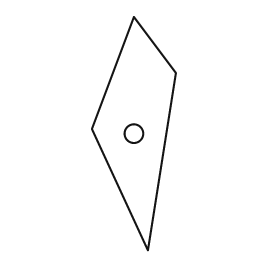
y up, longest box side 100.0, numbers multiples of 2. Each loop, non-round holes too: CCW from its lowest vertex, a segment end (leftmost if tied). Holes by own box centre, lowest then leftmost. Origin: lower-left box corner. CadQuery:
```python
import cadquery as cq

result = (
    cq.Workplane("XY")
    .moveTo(24.0, 0.0)
    .lineTo(36.0, 76.0)
    .lineTo(18.0, 100.0)
    .lineTo(0.0, 52.0)
    .close()
    .moveTo(18.0, 50.0)
    .circle(4.0)
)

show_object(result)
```